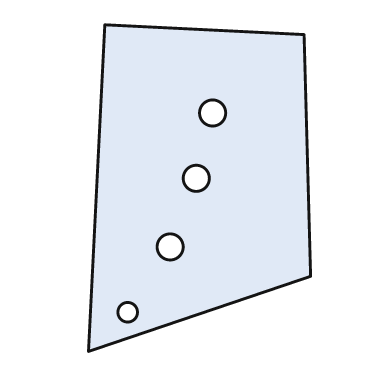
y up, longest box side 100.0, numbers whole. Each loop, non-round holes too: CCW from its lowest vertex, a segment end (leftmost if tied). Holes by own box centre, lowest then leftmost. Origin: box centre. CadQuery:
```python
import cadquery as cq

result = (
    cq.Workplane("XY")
    .moveTo(-34.0, -50.0)
    .lineTo(34.0, -27.0)
    .lineTo(32.0, 47.0)
    .lineTo(-29.0, 50.0)
    .close()
    .moveTo(-22.0, -38.0)
    .circle(3.0)
    .moveTo(-9.0, -18.0)
    .circle(4.0)
    .moveTo(-1.0, 3.0)
    .circle(4.0)
    .moveTo(4.0, 23.0)
    .circle(4.0)
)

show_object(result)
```